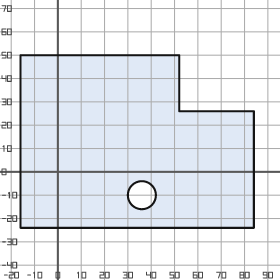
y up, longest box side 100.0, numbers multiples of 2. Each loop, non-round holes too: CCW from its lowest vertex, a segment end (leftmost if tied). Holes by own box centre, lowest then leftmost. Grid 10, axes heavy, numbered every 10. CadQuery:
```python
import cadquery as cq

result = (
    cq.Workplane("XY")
    .moveTo(-16.0, -24.0)
    .lineTo(84.0, -24.0)
    .lineTo(84.0, 26.0)
    .lineTo(52.0, 26.0)
    .lineTo(52.0, 50.0)
    .lineTo(-16.0, 50.0)
    .close()
    .moveTo(36.0, -10.0)
    .circle(6.0)
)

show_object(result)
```